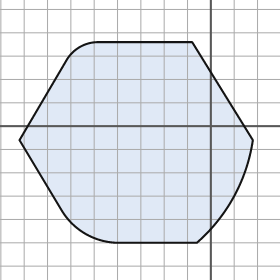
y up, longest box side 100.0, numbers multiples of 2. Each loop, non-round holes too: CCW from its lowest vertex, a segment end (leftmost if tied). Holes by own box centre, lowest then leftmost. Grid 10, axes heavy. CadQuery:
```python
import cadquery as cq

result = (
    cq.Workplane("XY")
    .moveTo(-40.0, -50.0)
    .lineTo(-6.0, -50.0)
    .threePointArc((10.0, -30.0), (18.0, -6.0))
    .lineTo(-8.0, 36.0)
    .lineTo(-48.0, 36.0)
    .threePointArc((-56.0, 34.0), (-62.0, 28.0))
    .lineTo(-82.0, -6.0)
    .lineTo(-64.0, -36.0)
    .threePointArc((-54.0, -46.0), (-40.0, -50.0))
    .close()
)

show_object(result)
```